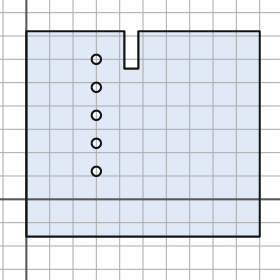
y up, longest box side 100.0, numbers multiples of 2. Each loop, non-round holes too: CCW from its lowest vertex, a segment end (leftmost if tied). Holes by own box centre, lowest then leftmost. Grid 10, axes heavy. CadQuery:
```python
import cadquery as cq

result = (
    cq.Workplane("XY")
    .moveTo(0.0, -16.0)
    .lineTo(100.0, -16.0)
    .lineTo(100.0, 72.0)
    .lineTo(48.0, 72.0)
    .lineTo(48.0, 56.0)
    .lineTo(42.0, 56.0)
    .lineTo(42.0, 72.0)
    .lineTo(0.0, 72.0)
    .close()
    .moveTo(30.0, 12.0)
    .circle(2.0)
    .moveTo(30.0, 24.0)
    .circle(2.0)
    .moveTo(30.0, 36.0)
    .circle(2.0)
    .moveTo(30.0, 48.0)
    .circle(2.0)
    .moveTo(30.0, 60.0)
    .circle(2.0)
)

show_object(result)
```